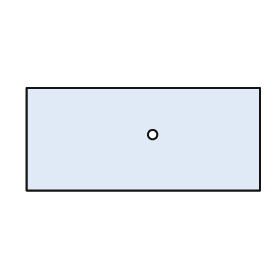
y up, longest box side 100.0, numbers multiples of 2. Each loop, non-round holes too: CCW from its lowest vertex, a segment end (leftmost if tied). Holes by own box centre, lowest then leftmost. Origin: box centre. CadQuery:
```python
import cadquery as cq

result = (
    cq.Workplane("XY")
    .moveTo(-50.0, -22.0)
    .lineTo(50.0, -22.0)
    .lineTo(50.0, 22.0)
    .lineTo(-50.0, 22.0)
    .close()
    .moveTo(4.0, 2.0)
    .circle(2.0)
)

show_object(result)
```